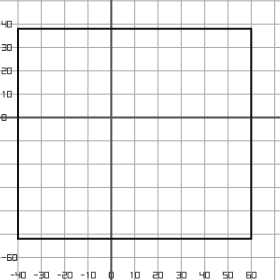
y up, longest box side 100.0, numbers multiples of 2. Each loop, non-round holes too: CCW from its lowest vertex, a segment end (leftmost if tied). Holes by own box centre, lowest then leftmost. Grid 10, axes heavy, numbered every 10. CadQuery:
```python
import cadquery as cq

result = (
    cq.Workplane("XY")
    .moveTo(-40.0, -52.0)
    .lineTo(60.0, -52.0)
    .lineTo(60.0, 38.0)
    .lineTo(-40.0, 38.0)
    .close()
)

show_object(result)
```